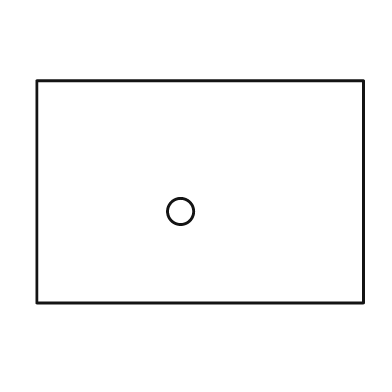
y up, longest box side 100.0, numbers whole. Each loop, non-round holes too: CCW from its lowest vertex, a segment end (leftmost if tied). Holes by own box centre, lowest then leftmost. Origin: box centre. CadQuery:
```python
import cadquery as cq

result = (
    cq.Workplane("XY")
    .moveTo(-50.0, -34.0)
    .lineTo(50.0, -34.0)
    .lineTo(50.0, 34.0)
    .lineTo(-50.0, 34.0)
    .close()
    .moveTo(-6.0, -6.0)
    .circle(4.0)
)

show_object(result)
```